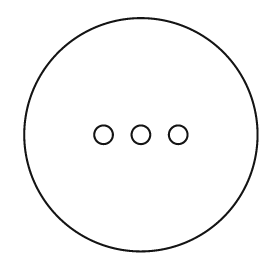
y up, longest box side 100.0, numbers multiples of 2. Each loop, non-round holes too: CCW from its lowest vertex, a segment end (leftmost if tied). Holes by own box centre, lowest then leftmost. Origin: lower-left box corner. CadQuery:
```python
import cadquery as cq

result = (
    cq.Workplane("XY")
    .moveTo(50.0, 50.0)
    .circle(50.0)
    .moveTo(34.0, 50.0)
    .circle(4.0)
    .moveTo(50.0, 50.0)
    .circle(4.0)
    .moveTo(66.0, 50.0)
    .circle(4.0)
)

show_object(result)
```